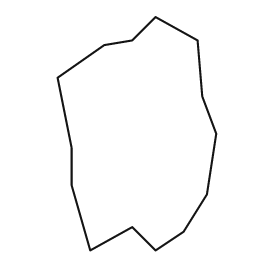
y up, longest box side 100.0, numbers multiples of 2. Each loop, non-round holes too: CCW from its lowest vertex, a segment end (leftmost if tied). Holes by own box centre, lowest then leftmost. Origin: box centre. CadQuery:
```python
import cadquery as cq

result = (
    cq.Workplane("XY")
    .moveTo(-20.0, -50.0)
    .lineTo(-2.0, -40.0)
    .lineTo(8.0, -50.0)
    .lineTo(20.0, -42.0)
    .lineTo(30.0, -26.0)
    .lineTo(34.0, 0.0)
    .lineTo(28.0, 16.0)
    .lineTo(26.0, 40.0)
    .lineTo(8.0, 50.0)
    .lineTo(-2.0, 40.0)
    .lineTo(-14.0, 38.0)
    .lineTo(-34.0, 24.0)
    .lineTo(-28.0, -6.0)
    .lineTo(-28.0, -22.0)
    .close()
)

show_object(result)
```